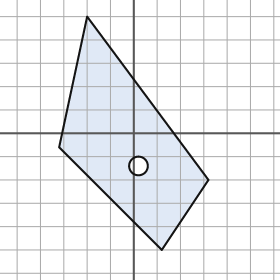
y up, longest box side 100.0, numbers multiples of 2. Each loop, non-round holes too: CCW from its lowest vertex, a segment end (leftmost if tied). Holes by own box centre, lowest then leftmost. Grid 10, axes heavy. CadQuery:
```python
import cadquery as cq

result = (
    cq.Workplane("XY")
    .moveTo(12.0, -50.0)
    .lineTo(32.0, -20.0)
    .lineTo(-20.0, 50.0)
    .lineTo(-32.0, -6.0)
    .close()
    .moveTo(2.0, -14.0)
    .circle(4.0)
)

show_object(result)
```